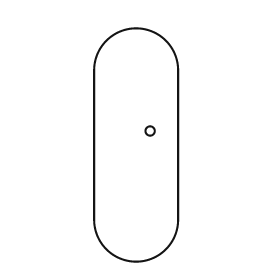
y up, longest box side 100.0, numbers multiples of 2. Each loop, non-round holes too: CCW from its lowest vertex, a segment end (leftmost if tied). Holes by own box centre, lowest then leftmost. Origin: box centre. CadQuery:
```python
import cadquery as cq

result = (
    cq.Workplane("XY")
    .moveTo(-18.0, -32.0)
    .threePointArc((0.0, -50.0), (18.0, -32.0))
    .lineTo(18.0, 32.0)
    .threePointArc((0.0, 50.0), (-18.0, 32.0))
    .close()
    .moveTo(6.0, 6.0)
    .circle(2.0)
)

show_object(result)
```